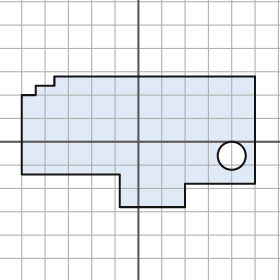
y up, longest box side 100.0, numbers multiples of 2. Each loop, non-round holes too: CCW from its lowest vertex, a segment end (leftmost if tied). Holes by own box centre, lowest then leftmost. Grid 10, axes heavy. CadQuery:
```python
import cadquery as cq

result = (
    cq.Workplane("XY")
    .moveTo(-8.0, -28.0)
    .lineTo(20.0, -28.0)
    .lineTo(20.0, -18.0)
    .lineTo(50.0, -18.0)
    .lineTo(50.0, 28.0)
    .lineTo(-36.0, 28.0)
    .lineTo(-36.0, 24.0)
    .lineTo(-44.0, 24.0)
    .lineTo(-44.0, 20.0)
    .lineTo(-50.0, 20.0)
    .lineTo(-50.0, -14.0)
    .lineTo(-8.0, -14.0)
    .close()
    .moveTo(40.0, -6.0)
    .circle(6.0)
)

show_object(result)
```